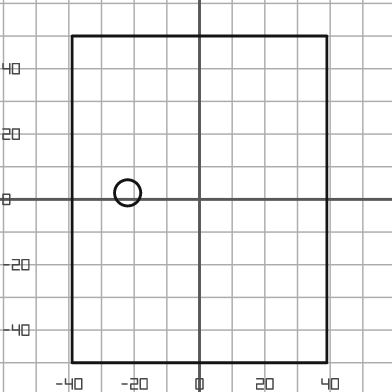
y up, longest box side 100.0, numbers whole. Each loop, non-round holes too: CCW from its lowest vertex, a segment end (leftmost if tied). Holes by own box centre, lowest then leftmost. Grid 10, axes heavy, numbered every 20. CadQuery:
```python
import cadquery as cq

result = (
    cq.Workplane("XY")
    .moveTo(-39.0, -50.0)
    .lineTo(39.0, -50.0)
    .lineTo(39.0, 50.0)
    .lineTo(-39.0, 50.0)
    .close()
    .moveTo(-22.0, 2.0)
    .circle(4.0)
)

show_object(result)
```